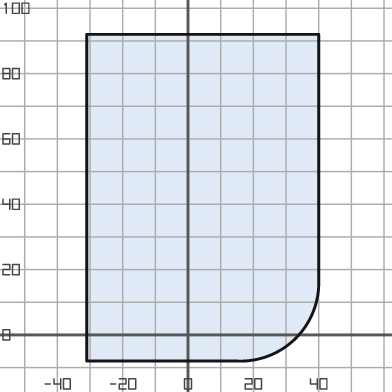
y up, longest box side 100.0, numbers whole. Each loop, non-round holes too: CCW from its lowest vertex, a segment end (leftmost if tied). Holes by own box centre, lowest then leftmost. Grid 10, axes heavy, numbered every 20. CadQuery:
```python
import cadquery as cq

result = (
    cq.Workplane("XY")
    .moveTo(-31.0, -8.0)
    .lineTo(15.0, -8.0)
    .threePointArc((33.0, -1.0), (40.0, 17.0))
    .lineTo(40.0, 92.0)
    .lineTo(-31.0, 92.0)
    .close()
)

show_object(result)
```